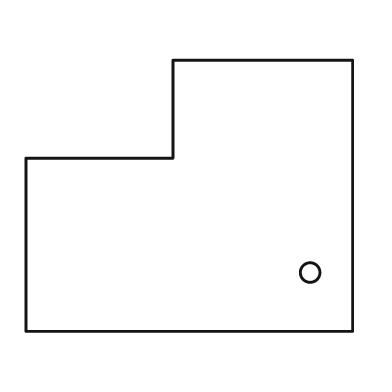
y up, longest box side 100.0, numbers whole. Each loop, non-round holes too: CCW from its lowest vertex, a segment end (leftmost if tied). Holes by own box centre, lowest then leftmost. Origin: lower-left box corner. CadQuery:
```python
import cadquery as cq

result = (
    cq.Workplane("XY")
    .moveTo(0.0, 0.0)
    .lineTo(100.0, 0.0)
    .lineTo(100.0, 83.0)
    .lineTo(45.0, 83.0)
    .lineTo(45.0, 53.0)
    .lineTo(0.0, 53.0)
    .close()
    .moveTo(87.0, 18.0)
    .circle(3.0)
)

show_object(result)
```